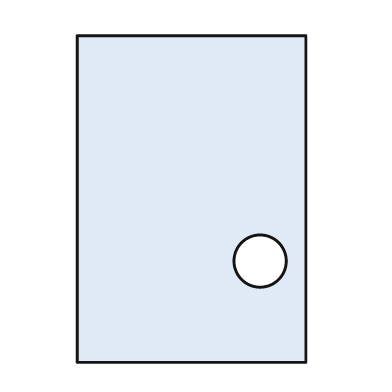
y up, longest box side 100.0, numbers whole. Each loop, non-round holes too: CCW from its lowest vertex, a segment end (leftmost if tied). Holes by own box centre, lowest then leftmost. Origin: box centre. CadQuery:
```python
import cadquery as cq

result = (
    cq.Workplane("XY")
    .moveTo(-35.0, -50.0)
    .lineTo(35.0, -50.0)
    .lineTo(35.0, 50.0)
    .lineTo(-35.0, 50.0)
    .close()
    .moveTo(21.0, -19.0)
    .circle(8.0)
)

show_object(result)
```